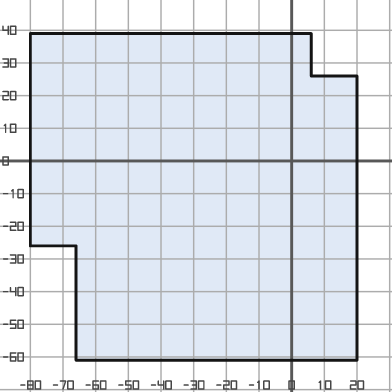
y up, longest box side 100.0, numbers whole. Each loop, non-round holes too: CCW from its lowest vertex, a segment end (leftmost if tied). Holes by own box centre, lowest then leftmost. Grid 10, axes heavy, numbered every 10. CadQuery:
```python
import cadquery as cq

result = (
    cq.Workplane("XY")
    .moveTo(-66.0, -61.0)
    .lineTo(20.0, -61.0)
    .lineTo(20.0, 26.0)
    .lineTo(6.0, 26.0)
    .lineTo(6.0, 39.0)
    .lineTo(-80.0, 39.0)
    .lineTo(-80.0, -26.0)
    .lineTo(-66.0, -26.0)
    .close()
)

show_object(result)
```